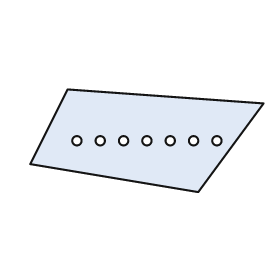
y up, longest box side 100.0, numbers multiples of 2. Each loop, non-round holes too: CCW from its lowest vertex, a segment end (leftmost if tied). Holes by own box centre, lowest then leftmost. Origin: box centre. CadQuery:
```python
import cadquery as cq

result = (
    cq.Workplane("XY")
    .moveTo(22.0, -22.0)
    .lineTo(50.0, 16.0)
    .lineTo(-34.0, 22.0)
    .lineTo(-50.0, -10.0)
    .close()
    .moveTo(-30.0, 0.0)
    .circle(2.0)
    .moveTo(-20.0, 0.0)
    .circle(2.0)
    .moveTo(-10.0, 0.0)
    .circle(2.0)
    .moveTo(0.0, 0.0)
    .circle(2.0)
    .moveTo(10.0, 0.0)
    .circle(2.0)
    .moveTo(20.0, 0.0)
    .circle(2.0)
    .moveTo(30.0, 0.0)
    .circle(2.0)
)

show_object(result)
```